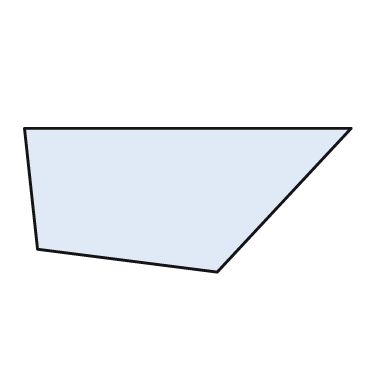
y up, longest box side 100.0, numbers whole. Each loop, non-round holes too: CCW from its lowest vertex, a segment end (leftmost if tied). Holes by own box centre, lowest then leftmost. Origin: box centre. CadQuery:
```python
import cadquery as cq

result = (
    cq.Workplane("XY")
    .moveTo(9.0, -22.0)
    .lineTo(50.0, 22.0)
    .lineTo(-50.0, 22.0)
    .lineTo(-46.0, -15.0)
    .close()
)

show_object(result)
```